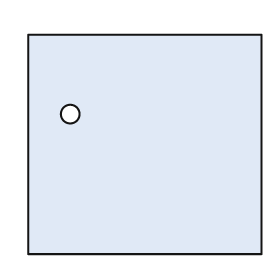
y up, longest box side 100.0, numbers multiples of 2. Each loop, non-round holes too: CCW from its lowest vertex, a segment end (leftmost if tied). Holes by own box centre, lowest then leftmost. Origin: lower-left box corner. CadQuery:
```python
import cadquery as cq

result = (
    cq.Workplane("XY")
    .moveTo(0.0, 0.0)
    .lineTo(100.0, 0.0)
    .lineTo(100.0, 94.0)
    .lineTo(0.0, 94.0)
    .close()
    .moveTo(18.0, 60.0)
    .circle(4.0)
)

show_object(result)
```